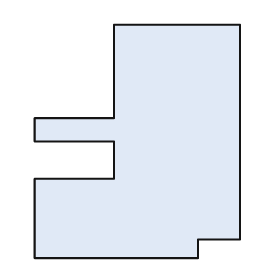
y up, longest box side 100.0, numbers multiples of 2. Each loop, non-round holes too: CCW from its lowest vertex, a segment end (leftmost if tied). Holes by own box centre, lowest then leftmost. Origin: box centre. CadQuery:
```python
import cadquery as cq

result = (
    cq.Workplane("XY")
    .moveTo(-44.0, -50.0)
    .lineTo(26.0, -50.0)
    .lineTo(26.0, -42.0)
    .lineTo(44.0, -42.0)
    .lineTo(44.0, 50.0)
    .lineTo(-10.0, 50.0)
    .lineTo(-10.0, 10.0)
    .lineTo(-44.0, 10.0)
    .lineTo(-44.0, 0.0)
    .lineTo(-10.0, 0.0)
    .lineTo(-10.0, -16.0)
    .lineTo(-44.0, -16.0)
    .close()
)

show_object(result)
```